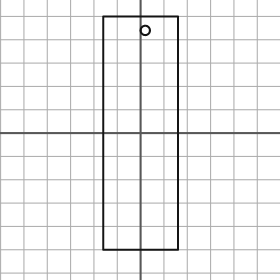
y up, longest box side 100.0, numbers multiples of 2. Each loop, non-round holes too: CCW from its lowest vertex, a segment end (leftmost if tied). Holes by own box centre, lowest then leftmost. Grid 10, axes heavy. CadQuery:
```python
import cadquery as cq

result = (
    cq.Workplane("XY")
    .moveTo(-16.0, -50.0)
    .lineTo(16.0, -50.0)
    .lineTo(16.0, 50.0)
    .lineTo(-16.0, 50.0)
    .close()
    .moveTo(2.0, 44.0)
    .circle(2.0)
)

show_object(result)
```